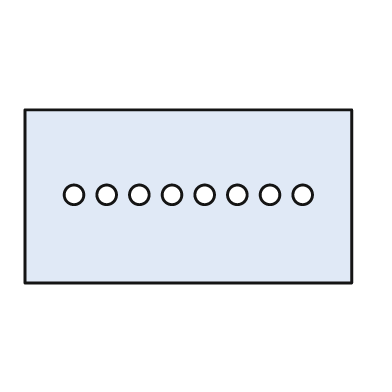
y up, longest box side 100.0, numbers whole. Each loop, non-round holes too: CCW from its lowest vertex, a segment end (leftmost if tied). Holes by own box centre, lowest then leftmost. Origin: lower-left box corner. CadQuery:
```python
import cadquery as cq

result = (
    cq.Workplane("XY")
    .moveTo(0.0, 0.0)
    .lineTo(100.0, 0.0)
    .lineTo(100.0, 53.0)
    .lineTo(0.0, 53.0)
    .close()
    .moveTo(15.0, 27.0)
    .circle(3.0)
    .moveTo(25.0, 27.0)
    .circle(3.0)
    .moveTo(35.0, 27.0)
    .circle(3.0)
    .moveTo(45.0, 27.0)
    .circle(3.0)
    .moveTo(55.0, 27.0)
    .circle(3.0)
    .moveTo(65.0, 27.0)
    .circle(3.0)
    .moveTo(75.0, 27.0)
    .circle(3.0)
    .moveTo(85.0, 27.0)
    .circle(3.0)
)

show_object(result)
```